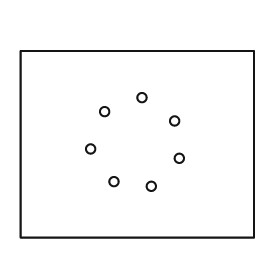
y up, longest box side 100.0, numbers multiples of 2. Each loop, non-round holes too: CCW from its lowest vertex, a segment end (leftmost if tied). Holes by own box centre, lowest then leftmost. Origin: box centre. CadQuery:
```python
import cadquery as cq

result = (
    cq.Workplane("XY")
    .moveTo(-50.0, -40.0)
    .lineTo(50.0, -40.0)
    .lineTo(50.0, 40.0)
    .lineTo(-50.0, 40.0)
    .close()
    .moveTo(6.0, -18.0)
    .circle(2.0)
    .moveTo(-10.0, -16.0)
    .circle(2.0)
    .moveTo(18.0, -6.0)
    .circle(2.0)
    .moveTo(-20.0, -2.0)
    .circle(2.0)
    .moveTo(16.0, 10.0)
    .circle(2.0)
    .moveTo(-14.0, 14.0)
    .circle(2.0)
    .moveTo(2.0, 20.0)
    .circle(2.0)
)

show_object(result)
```